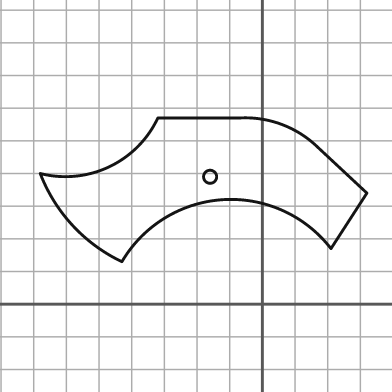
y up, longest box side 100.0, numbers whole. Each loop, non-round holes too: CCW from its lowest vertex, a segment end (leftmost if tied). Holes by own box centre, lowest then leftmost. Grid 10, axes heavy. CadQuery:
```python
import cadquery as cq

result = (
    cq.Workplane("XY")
    .moveTo(-43.0, 13.0)
    .threePointArc((-12.0, 32.0), (21.0, 17.0))
    .lineTo(32.0, 34.0)
    .lineTo(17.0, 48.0)
    .threePointArc((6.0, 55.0), (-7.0, 57.0))
    .lineTo(-32.0, 57.0)
    .threePointArc((-47.0, 42.0), (-68.0, 40.0))
    .threePointArc((-58.0, 24.0), (-43.0, 13.0))
    .close()
    .moveTo(-16.0, 39.0)
    .circle(2.0)
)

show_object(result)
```